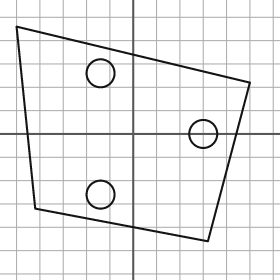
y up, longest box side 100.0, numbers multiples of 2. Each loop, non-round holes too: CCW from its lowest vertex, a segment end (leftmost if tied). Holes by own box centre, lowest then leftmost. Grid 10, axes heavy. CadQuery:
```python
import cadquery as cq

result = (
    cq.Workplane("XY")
    .moveTo(32.0, -46.0)
    .lineTo(50.0, 22.0)
    .lineTo(-50.0, 46.0)
    .lineTo(-42.0, -32.0)
    .close()
    .moveTo(-14.0, -26.0)
    .circle(6.0)
    .moveTo(30.0, 0.0)
    .circle(6.0)
    .moveTo(-14.0, 26.0)
    .circle(6.0)
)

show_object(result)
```